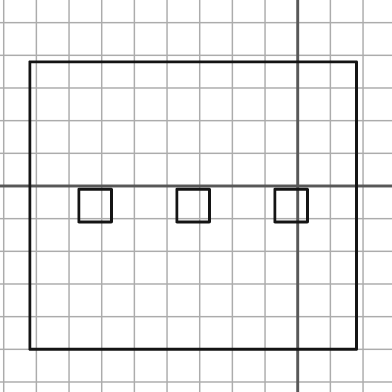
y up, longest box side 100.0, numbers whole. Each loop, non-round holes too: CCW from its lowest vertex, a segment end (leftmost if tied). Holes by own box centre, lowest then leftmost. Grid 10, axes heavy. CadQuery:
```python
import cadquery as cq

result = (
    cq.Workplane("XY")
    .moveTo(-82.0, -50.0)
    .lineTo(18.0, -50.0)
    .lineTo(18.0, 38.0)
    .lineTo(-82.0, 38.0)
    .close()
    .moveTo(-67.0, -11.0)
    .lineTo(-57.0, -11.0)
    .lineTo(-57.0, -1.0)
    .lineTo(-67.0, -1.0)
    .close()
    .moveTo(-37.0, -11.0)
    .lineTo(-27.0, -11.0)
    .lineTo(-27.0, -1.0)
    .lineTo(-37.0, -1.0)
    .close()
    .moveTo(-7.0, -11.0)
    .lineTo(3.0, -11.0)
    .lineTo(3.0, -1.0)
    .lineTo(-7.0, -1.0)
    .close()
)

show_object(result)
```